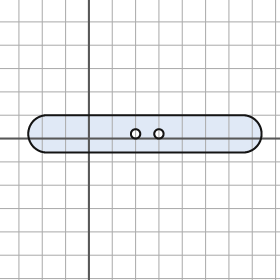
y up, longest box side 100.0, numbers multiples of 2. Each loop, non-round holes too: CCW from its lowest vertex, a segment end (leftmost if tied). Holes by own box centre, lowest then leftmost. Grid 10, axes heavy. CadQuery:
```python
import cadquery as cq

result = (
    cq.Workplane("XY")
    .moveTo(-18.0, -6.0)
    .lineTo(66.0, -6.0)
    .threePointArc((74.0, 2.0), (66.0, 10.0))
    .lineTo(-18.0, 10.0)
    .threePointArc((-26.0, 2.0), (-18.0, -6.0))
    .close()
    .moveTo(20.0, 2.0)
    .circle(2.0)
    .moveTo(30.0, 2.0)
    .circle(2.0)
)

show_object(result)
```